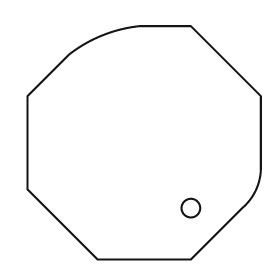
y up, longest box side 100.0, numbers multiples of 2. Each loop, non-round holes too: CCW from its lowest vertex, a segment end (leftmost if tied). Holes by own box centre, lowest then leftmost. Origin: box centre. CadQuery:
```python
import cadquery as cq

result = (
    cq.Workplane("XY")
    .moveTo(-20.0, -50.0)
    .lineTo(20.0, -50.0)
    .lineTo(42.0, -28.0)
    .threePointArc((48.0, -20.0), (50.0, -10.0))
    .lineTo(50.0, 20.0)
    .lineTo(20.0, 50.0)
    .lineTo(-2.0, 50.0)
    .threePointArc((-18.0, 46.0), (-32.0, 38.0))
    .lineTo(-50.0, 20.0)
    .lineTo(-50.0, -20.0)
    .close()
    .moveTo(20.0, -28.0)
    .circle(4.0)
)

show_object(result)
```